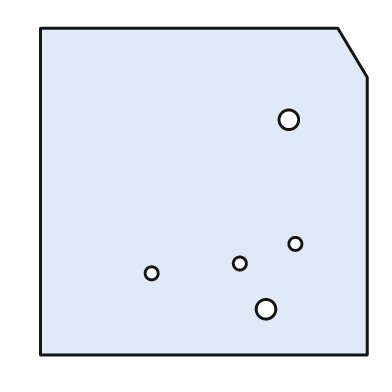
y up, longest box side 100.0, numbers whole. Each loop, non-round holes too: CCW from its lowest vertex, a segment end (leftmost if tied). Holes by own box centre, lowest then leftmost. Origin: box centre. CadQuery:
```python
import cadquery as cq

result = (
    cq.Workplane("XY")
    .moveTo(-50.0, -50.0)
    .lineTo(50.0, -50.0)
    .lineTo(50.0, 35.0)
    .lineTo(41.0, 50.0)
    .lineTo(-50.0, 50.0)
    .close()
    .moveTo(19.0, -36.0)
    .circle(3.0)
    .moveTo(-16.0, -25.0)
    .circle(2.0)
    .moveTo(11.0, -22.0)
    .circle(2.0)
    .moveTo(28.0, -16.0)
    .circle(2.0)
    .moveTo(26.0, 22.0)
    .circle(3.0)
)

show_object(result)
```